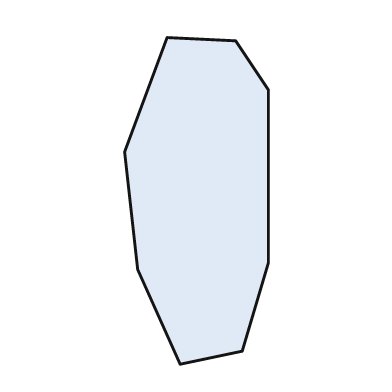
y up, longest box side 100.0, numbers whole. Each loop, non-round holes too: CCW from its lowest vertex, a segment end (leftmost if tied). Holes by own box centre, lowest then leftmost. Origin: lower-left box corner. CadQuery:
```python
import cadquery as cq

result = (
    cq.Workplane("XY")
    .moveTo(17.0, 0.0)
    .lineTo(36.0, 4.0)
    .lineTo(44.0, 31.0)
    .lineTo(44.0, 84.0)
    .lineTo(34.0, 99.0)
    .lineTo(13.0, 100.0)
    .lineTo(0.0, 65.0)
    .lineTo(4.0, 29.0)
    .close()
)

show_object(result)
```